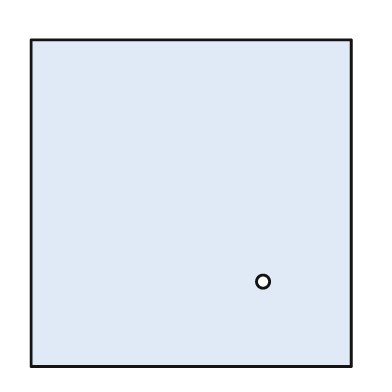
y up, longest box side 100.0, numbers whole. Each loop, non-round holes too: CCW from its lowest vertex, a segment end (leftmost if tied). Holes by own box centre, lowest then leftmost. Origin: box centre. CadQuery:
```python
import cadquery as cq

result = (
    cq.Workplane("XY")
    .moveTo(-49.0, -50.0)
    .lineTo(49.0, -50.0)
    .lineTo(49.0, 50.0)
    .lineTo(-49.0, 50.0)
    .close()
    .moveTo(22.0, -24.0)
    .circle(2.0)
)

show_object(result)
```